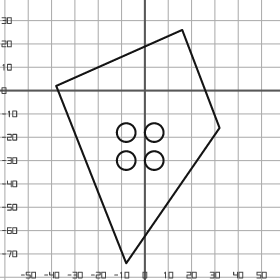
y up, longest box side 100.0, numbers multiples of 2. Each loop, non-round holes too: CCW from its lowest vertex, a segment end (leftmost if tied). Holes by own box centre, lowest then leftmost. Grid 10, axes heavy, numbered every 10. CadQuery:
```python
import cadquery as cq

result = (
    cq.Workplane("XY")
    .moveTo(-8.0, -74.0)
    .lineTo(32.0, -16.0)
    .lineTo(16.0, 26.0)
    .lineTo(-38.0, 2.0)
    .close()
    .moveTo(-8.0, -30.0)
    .circle(4.0)
    .moveTo(4.0, -30.0)
    .circle(4.0)
    .moveTo(-8.0, -18.0)
    .circle(4.0)
    .moveTo(4.0, -18.0)
    .circle(4.0)
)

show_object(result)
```